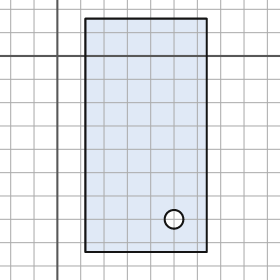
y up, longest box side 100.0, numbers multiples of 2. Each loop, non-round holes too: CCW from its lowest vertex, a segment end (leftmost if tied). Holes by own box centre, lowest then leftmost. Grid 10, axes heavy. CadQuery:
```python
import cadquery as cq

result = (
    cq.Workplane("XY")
    .moveTo(12.0, -84.0)
    .lineTo(64.0, -84.0)
    .lineTo(64.0, 16.0)
    .lineTo(12.0, 16.0)
    .close()
    .moveTo(50.0, -70.0)
    .circle(4.0)
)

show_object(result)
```